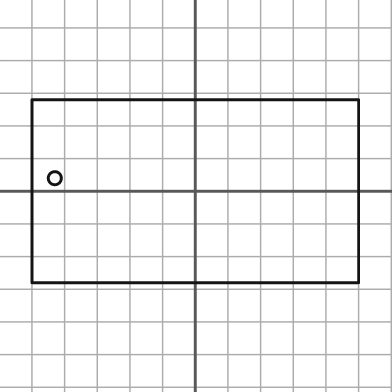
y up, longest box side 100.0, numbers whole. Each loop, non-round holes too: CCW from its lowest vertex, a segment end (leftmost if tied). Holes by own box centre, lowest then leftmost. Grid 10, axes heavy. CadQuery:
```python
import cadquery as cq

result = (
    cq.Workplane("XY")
    .moveTo(-50.0, -28.0)
    .lineTo(50.0, -28.0)
    .lineTo(50.0, 28.0)
    .lineTo(-50.0, 28.0)
    .close()
    .moveTo(-43.0, 4.0)
    .circle(2.0)
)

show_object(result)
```